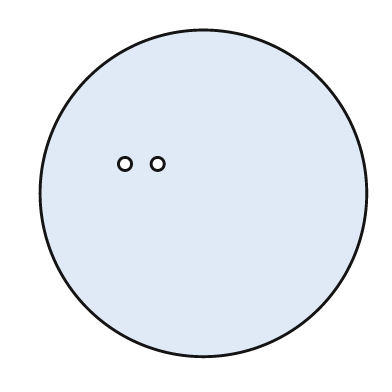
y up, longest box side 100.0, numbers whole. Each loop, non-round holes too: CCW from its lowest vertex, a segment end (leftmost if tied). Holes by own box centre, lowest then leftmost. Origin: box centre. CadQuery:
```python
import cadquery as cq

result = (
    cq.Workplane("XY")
    .moveTo(0.0, 0.0)
    .circle(50.0)
    .moveTo(-24.0, 9.0)
    .circle(2.0)
    .moveTo(-14.0, 9.0)
    .circle(2.0)
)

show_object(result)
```